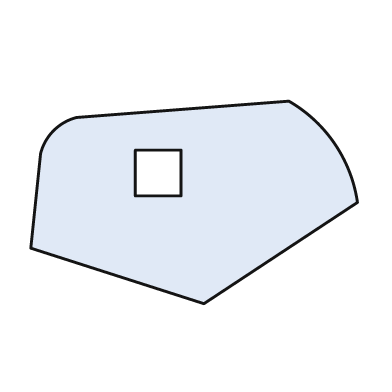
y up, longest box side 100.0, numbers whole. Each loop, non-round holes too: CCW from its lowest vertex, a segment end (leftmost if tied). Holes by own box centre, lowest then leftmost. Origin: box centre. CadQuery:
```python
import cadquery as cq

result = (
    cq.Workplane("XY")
    .moveTo(3.0, -31.0)
    .lineTo(50.0, 0.0)
    .threePointArc((43.0, 18.0), (29.0, 31.0))
    .lineTo(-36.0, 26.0)
    .threePointArc((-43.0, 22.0), (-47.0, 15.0))
    .lineTo(-50.0, -14.0)
    .close()
    .moveTo(-18.0, 2.0)
    .lineTo(-4.0, 2.0)
    .lineTo(-4.0, 16.0)
    .lineTo(-18.0, 16.0)
    .close()
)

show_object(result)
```